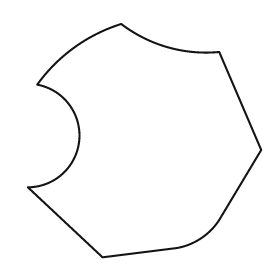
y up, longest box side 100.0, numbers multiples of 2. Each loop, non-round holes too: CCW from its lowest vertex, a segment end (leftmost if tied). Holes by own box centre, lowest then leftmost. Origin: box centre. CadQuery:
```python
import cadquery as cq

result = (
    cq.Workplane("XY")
    .moveTo(-18.0, -50.0)
    .lineTo(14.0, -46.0)
    .threePointArc((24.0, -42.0), (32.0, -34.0))
    .lineTo(50.0, -4.0)
    .lineTo(32.0, 38.0)
    .threePointArc((10.0, 40.0), (-10.0, 50.0))
    .threePointArc((-30.0, 40.0), (-46.0, 24.0))
    .threePointArc((-28.0, 0.0), (-50.0, -20.0))
    .close()
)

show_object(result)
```